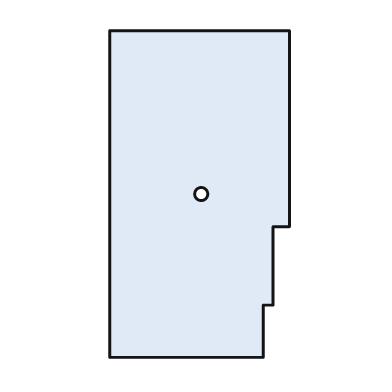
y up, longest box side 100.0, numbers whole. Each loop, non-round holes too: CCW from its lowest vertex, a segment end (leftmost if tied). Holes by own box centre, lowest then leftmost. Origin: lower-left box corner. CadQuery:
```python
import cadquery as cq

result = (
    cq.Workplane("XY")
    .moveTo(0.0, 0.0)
    .lineTo(47.0, 0.0)
    .lineTo(47.0, 16.0)
    .lineTo(50.0, 16.0)
    .lineTo(50.0, 40.0)
    .lineTo(55.0, 40.0)
    .lineTo(55.0, 100.0)
    .lineTo(0.0, 100.0)
    .close()
    .moveTo(28.0, 50.0)
    .circle(2.0)
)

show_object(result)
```